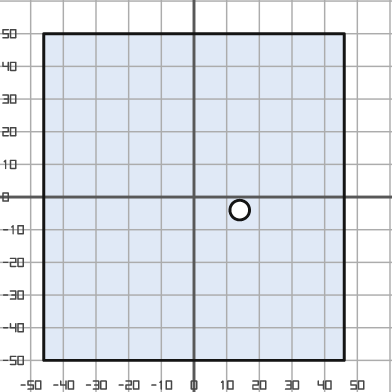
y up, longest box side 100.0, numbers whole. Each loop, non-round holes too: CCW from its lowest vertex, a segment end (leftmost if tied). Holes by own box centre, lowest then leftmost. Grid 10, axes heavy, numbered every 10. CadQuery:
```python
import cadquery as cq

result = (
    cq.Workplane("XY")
    .moveTo(-46.0, -50.0)
    .lineTo(46.0, -50.0)
    .lineTo(46.0, 50.0)
    .lineTo(-46.0, 50.0)
    .close()
    .moveTo(14.0, -4.0)
    .circle(3.0)
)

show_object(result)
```